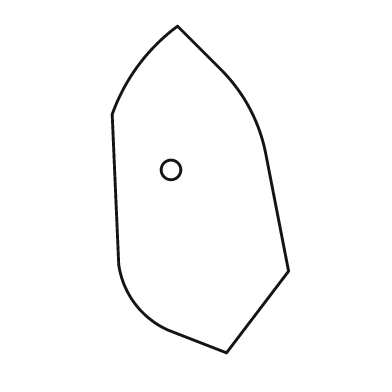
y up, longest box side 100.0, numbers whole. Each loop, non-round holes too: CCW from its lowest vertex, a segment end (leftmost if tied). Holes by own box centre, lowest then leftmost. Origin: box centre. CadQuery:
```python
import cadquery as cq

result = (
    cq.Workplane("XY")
    .moveTo(8.0, -50.0)
    .lineTo(27.0, -25.0)
    .lineTo(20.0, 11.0)
    .threePointArc((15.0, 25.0), (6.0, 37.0))
    .lineTo(-7.0, 50.0)
    .threePointArc((-19.0, 38.0), (-27.0, 23.0))
    .lineTo(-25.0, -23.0)
    .threePointArc((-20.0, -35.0), (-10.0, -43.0))
    .close()
    .moveTo(-9.0, 6.0)
    .circle(3.0)
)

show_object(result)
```